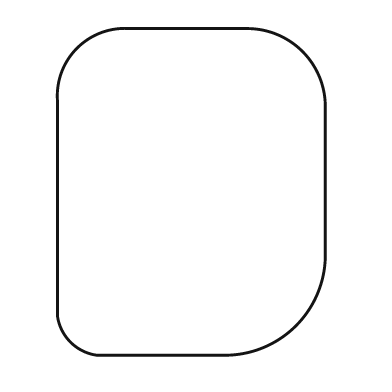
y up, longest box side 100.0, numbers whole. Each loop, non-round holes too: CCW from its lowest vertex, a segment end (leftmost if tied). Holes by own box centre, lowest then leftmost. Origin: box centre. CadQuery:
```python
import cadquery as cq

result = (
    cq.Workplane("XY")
    .moveTo(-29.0, -50.0)
    .lineTo(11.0, -50.0)
    .threePointArc((32.0, -41.0), (41.0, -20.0))
    .lineTo(41.0, 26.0)
    .threePointArc((34.0, 43.0), (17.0, 50.0))
    .lineTo(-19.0, 50.0)
    .threePointArc((-35.0, 44.0), (-41.0, 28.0))
    .lineTo(-41.0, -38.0)
    .threePointArc((-37.0, -46.0), (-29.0, -50.0))
    .close()
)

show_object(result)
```